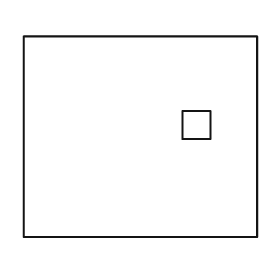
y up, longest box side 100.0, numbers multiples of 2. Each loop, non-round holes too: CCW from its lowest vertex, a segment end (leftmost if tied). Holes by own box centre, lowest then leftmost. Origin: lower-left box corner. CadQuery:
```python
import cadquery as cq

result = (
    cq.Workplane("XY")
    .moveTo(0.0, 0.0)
    .lineTo(100.0, 0.0)
    .lineTo(100.0, 86.0)
    .lineTo(0.0, 86.0)
    .close()
    .moveTo(68.0, 42.0)
    .lineTo(80.0, 42.0)
    .lineTo(80.0, 54.0)
    .lineTo(68.0, 54.0)
    .close()
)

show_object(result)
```